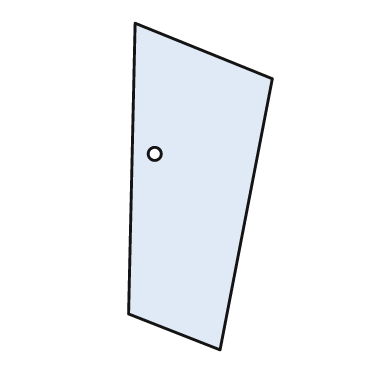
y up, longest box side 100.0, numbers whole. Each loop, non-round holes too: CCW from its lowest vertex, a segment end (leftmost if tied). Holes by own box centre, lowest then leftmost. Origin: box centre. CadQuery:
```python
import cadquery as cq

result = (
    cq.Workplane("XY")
    .moveTo(6.0, -50.0)
    .lineTo(22.0, 33.0)
    .lineTo(-20.0, 50.0)
    .lineTo(-22.0, -39.0)
    .close()
    .moveTo(-14.0, 10.0)
    .circle(2.0)
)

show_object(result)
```